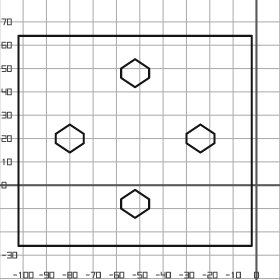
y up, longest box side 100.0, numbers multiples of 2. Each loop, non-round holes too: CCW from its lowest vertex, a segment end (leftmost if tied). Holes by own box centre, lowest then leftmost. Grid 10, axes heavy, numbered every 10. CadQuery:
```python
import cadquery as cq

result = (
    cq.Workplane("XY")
    .moveTo(-102.0, -26.0)
    .lineTo(-2.0, -26.0)
    .lineTo(-2.0, 64.0)
    .lineTo(-102.0, 64.0)
    .close()
    .moveTo(-52.0, -14.0)
    .lineTo(-46.0, -10.0)
    .lineTo(-46.0, -6.0)
    .lineTo(-52.0, -2.0)
    .lineTo(-58.0, -6.0)
    .lineTo(-58.0, -10.0)
    .close()
    .moveTo(-80.0, 14.0)
    .lineTo(-74.0, 18.0)
    .lineTo(-74.0, 22.0)
    .lineTo(-80.0, 26.0)
    .lineTo(-86.0, 22.0)
    .lineTo(-86.0, 18.0)
    .close()
    .moveTo(-24.0, 14.0)
    .lineTo(-18.0, 18.0)
    .lineTo(-18.0, 22.0)
    .lineTo(-24.0, 26.0)
    .lineTo(-30.0, 22.0)
    .lineTo(-30.0, 18.0)
    .close()
    .moveTo(-52.0, 42.0)
    .lineTo(-46.0, 46.0)
    .lineTo(-46.0, 50.0)
    .lineTo(-52.0, 54.0)
    .lineTo(-58.0, 50.0)
    .lineTo(-58.0, 46.0)
    .close()
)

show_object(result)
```